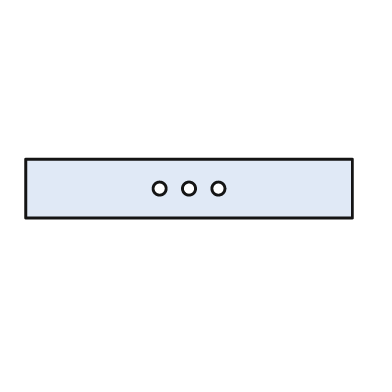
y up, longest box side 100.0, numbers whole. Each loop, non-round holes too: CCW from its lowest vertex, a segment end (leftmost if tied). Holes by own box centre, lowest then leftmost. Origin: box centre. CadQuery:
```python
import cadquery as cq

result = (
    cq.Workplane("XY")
    .moveTo(-50.0, -9.0)
    .lineTo(50.0, -9.0)
    .lineTo(50.0, 9.0)
    .lineTo(-50.0, 9.0)
    .close()
    .moveTo(-9.0, 0.0)
    .circle(2.0)
    .moveTo(0.0, 0.0)
    .circle(2.0)
    .moveTo(9.0, 0.0)
    .circle(2.0)
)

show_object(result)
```